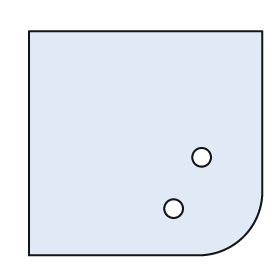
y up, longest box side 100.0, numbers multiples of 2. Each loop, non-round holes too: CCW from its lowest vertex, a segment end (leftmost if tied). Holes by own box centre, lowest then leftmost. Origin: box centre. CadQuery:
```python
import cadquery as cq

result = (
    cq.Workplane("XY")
    .moveTo(-50.0, -48.0)
    .lineTo(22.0, -48.0)
    .threePointArc((42.0, -40.0), (50.0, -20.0))
    .lineTo(50.0, 48.0)
    .lineTo(-50.0, 48.0)
    .close()
    .moveTo(12.0, -28.0)
    .circle(4.0)
    .moveTo(24.0, -6.0)
    .circle(4.0)
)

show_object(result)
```